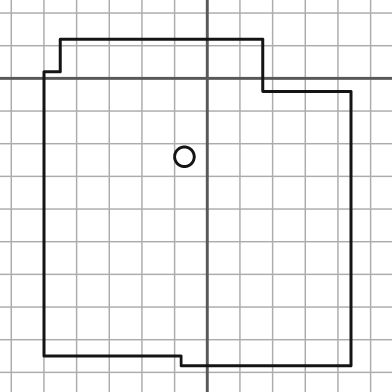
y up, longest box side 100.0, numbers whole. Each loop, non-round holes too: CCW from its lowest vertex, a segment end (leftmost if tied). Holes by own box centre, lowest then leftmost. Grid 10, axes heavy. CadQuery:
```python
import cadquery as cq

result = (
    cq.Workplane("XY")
    .moveTo(-8.0, -88.0)
    .lineTo(44.0, -88.0)
    .lineTo(44.0, -4.0)
    .lineTo(17.0, -4.0)
    .lineTo(17.0, 12.0)
    .lineTo(-45.0, 12.0)
    .lineTo(-45.0, 2.0)
    .lineTo(-50.0, 2.0)
    .lineTo(-50.0, -85.0)
    .lineTo(-8.0, -85.0)
    .close()
    .moveTo(-7.0, -24.0)
    .circle(3.0)
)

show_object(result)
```